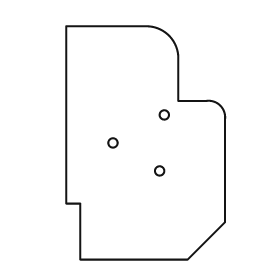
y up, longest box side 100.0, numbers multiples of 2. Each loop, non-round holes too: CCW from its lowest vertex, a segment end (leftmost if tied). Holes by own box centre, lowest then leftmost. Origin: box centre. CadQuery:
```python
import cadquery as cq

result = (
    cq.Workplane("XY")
    .moveTo(-28.0, -50.0)
    .lineTo(18.0, -50.0)
    .lineTo(34.0, -34.0)
    .lineTo(34.0, 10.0)
    .threePointArc((32.0, 16.0), (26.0, 18.0))
    .lineTo(14.0, 18.0)
    .lineTo(14.0, 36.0)
    .threePointArc((10.0, 46.0), (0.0, 50.0))
    .lineTo(-34.0, 50.0)
    .lineTo(-34.0, -26.0)
    .lineTo(-28.0, -26.0)
    .close()
    .moveTo(6.0, -12.0)
    .circle(2.0)
    .moveTo(-14.0, 0.0)
    .circle(2.0)
    .moveTo(8.0, 12.0)
    .circle(2.0)
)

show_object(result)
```